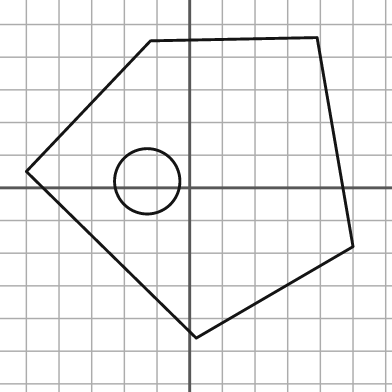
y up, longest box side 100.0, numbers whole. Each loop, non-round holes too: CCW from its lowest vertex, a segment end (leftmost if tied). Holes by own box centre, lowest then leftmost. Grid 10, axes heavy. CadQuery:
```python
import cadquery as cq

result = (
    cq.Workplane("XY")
    .moveTo(2.0, -46.0)
    .lineTo(50.0, -18.0)
    .lineTo(39.0, 46.0)
    .lineTo(-12.0, 45.0)
    .lineTo(-50.0, 5.0)
    .close()
    .moveTo(-13.0, 2.0)
    .circle(10.0)
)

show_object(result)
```